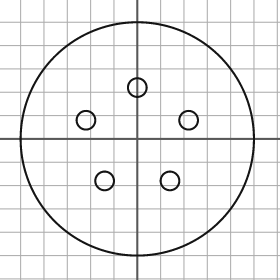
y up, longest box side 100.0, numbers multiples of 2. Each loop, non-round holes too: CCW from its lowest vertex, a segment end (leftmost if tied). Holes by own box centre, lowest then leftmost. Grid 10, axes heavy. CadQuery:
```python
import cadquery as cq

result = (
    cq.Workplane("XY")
    .moveTo(0.0, 0.0)
    .circle(50.0)
    .moveTo(-14.0, -18.0)
    .circle(4.0)
    .moveTo(14.0, -18.0)
    .circle(4.0)
    .moveTo(-22.0, 8.0)
    .circle(4.0)
    .moveTo(22.0, 8.0)
    .circle(4.0)
    .moveTo(0.0, 22.0)
    .circle(4.0)
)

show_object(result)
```